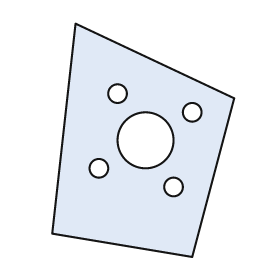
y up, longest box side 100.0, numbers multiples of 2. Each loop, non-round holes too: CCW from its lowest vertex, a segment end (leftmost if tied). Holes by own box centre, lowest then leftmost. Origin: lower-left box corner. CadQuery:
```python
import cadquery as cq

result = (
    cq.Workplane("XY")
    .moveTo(60.0, 0.0)
    .lineTo(78.0, 68.0)
    .lineTo(10.0, 100.0)
    .lineTo(0.0, 10.0)
    .close()
    .moveTo(52.0, 30.0)
    .circle(4.0)
    .moveTo(20.0, 38.0)
    .circle(4.0)
    .moveTo(40.0, 50.0)
    .circle(12.0)
    .moveTo(60.0, 62.0)
    .circle(4.0)
    .moveTo(28.0, 70.0)
    .circle(4.0)
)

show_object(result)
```